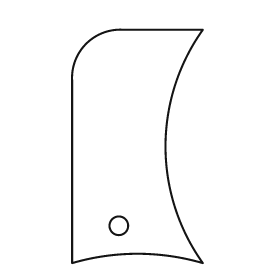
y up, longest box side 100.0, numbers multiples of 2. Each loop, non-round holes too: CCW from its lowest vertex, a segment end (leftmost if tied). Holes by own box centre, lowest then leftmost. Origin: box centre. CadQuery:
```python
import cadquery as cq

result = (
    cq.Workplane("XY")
    .moveTo(-28.0, -50.0)
    .threePointArc((0.0, -46.0), (28.0, -50.0))
    .threePointArc((12.0, 0.0), (28.0, 50.0))
    .lineTo(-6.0, 50.0)
    .threePointArc((-22.0, 44.0), (-28.0, 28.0))
    .close()
    .moveTo(-8.0, -34.0)
    .circle(4.0)
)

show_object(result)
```